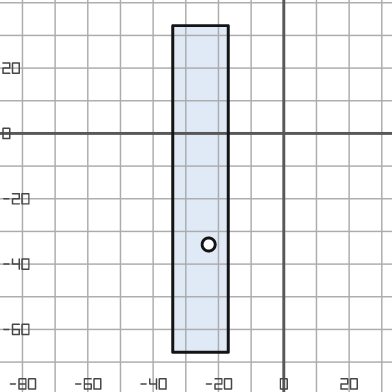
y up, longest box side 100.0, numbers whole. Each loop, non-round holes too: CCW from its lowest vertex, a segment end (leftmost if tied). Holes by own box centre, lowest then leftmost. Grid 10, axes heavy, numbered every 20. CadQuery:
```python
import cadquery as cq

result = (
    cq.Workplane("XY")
    .moveTo(-34.0, -67.0)
    .lineTo(-17.0, -67.0)
    .lineTo(-17.0, 33.0)
    .lineTo(-34.0, 33.0)
    .close()
    .moveTo(-23.0, -34.0)
    .circle(2.0)
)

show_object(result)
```